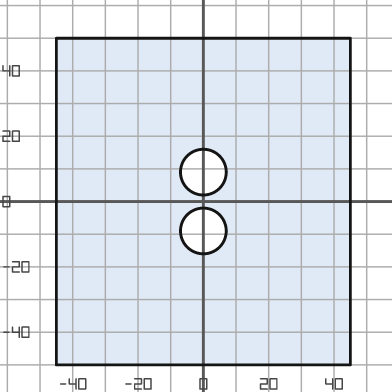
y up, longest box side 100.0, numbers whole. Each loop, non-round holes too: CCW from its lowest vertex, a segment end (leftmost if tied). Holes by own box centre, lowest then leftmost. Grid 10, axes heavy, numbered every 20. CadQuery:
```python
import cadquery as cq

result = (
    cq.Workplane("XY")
    .moveTo(-45.0, -50.0)
    .lineTo(45.0, -50.0)
    .lineTo(45.0, 50.0)
    .lineTo(-45.0, 50.0)
    .close()
    .moveTo(0.0, -9.0)
    .circle(7.0)
    .moveTo(0.0, 9.0)
    .circle(7.0)
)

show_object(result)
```